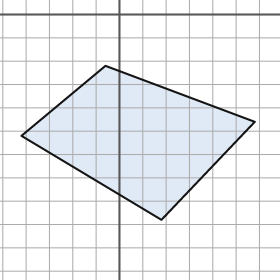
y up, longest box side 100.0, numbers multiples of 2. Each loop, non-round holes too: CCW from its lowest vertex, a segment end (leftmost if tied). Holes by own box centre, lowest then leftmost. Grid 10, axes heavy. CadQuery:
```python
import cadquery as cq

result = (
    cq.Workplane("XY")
    .moveTo(18.0, -88.0)
    .lineTo(58.0, -46.0)
    .lineTo(-6.0, -22.0)
    .lineTo(-42.0, -52.0)
    .close()
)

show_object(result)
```